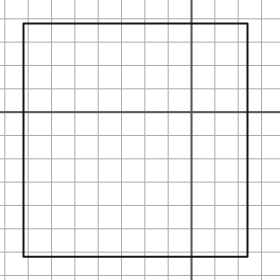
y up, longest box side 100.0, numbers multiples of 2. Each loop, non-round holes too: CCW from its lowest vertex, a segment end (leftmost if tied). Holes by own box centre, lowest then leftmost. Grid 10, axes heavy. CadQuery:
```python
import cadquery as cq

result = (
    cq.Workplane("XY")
    .moveTo(-72.0, -62.0)
    .lineTo(24.0, -62.0)
    .lineTo(24.0, 38.0)
    .lineTo(-72.0, 38.0)
    .close()
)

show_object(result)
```